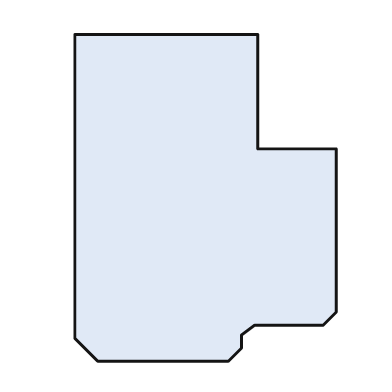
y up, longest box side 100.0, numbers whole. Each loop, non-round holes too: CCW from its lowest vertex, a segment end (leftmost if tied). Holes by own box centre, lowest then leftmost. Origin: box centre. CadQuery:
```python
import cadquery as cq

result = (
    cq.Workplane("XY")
    .moveTo(-33.0, -50.0)
    .lineTo(7.0, -50.0)
    .lineTo(11.0, -46.0)
    .lineTo(11.0, -42.0)
    .lineTo(15.0, -39.0)
    .lineTo(36.0, -39.0)
    .lineTo(40.0, -35.0)
    .lineTo(40.0, 15.0)
    .lineTo(16.0, 15.0)
    .lineTo(16.0, 50.0)
    .lineTo(-40.0, 50.0)
    .lineTo(-40.0, -43.0)
    .close()
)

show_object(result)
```